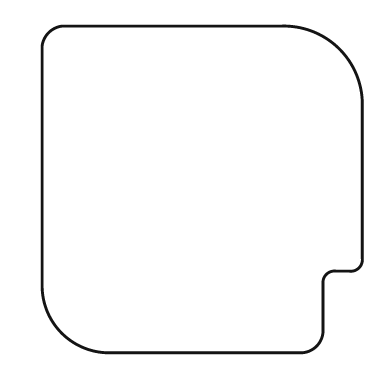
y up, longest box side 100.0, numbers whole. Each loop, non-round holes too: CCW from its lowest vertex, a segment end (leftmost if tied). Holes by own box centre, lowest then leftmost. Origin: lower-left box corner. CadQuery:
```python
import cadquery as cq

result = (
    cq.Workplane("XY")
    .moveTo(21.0, 0.0)
    .lineTo(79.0, 0.0)
    .threePointArc((84.0, 2.0), (86.0, 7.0))
    .lineTo(86.0, 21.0)
    .threePointArc((87.0, 24.0), (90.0, 25.0))
    .lineTo(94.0, 25.0)
    .threePointArc((97.0, 26.0), (98.0, 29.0))
    .lineTo(98.0, 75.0)
    .threePointArc((91.0, 93.0), (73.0, 100.0))
    .lineTo(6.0, 100.0)
    .threePointArc((2.0, 98.0), (0.0, 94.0))
    .lineTo(0.0, 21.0)
    .threePointArc((6.0, 6.0), (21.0, 0.0))
    .close()
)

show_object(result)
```